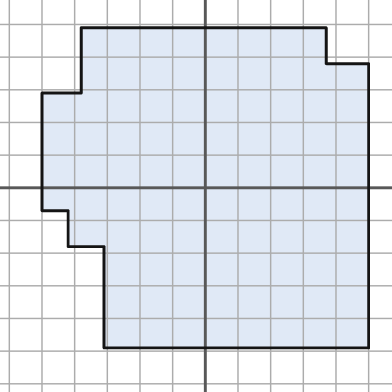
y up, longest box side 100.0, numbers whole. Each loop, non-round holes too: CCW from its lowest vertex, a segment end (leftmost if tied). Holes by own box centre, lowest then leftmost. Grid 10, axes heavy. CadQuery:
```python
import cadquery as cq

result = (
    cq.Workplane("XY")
    .moveTo(-31.0, -49.0)
    .lineTo(50.0, -49.0)
    .lineTo(50.0, 38.0)
    .lineTo(37.0, 38.0)
    .lineTo(37.0, 49.0)
    .lineTo(-38.0, 49.0)
    .lineTo(-38.0, 29.0)
    .lineTo(-50.0, 29.0)
    .lineTo(-50.0, -7.0)
    .lineTo(-42.0, -7.0)
    .lineTo(-42.0, -18.0)
    .lineTo(-31.0, -18.0)
    .close()
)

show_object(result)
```